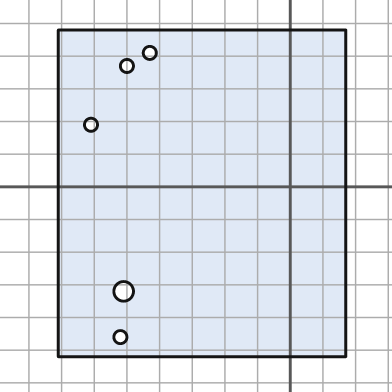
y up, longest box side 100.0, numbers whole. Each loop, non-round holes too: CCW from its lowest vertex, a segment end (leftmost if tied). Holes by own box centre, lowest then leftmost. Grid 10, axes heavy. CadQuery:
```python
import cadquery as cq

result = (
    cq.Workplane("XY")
    .moveTo(-71.0, -52.0)
    .lineTo(17.0, -52.0)
    .lineTo(17.0, 48.0)
    .lineTo(-71.0, 48.0)
    .close()
    .moveTo(-52.0, -46.0)
    .circle(2.0)
    .moveTo(-51.0, -32.0)
    .circle(3.0)
    .moveTo(-61.0, 19.0)
    .circle(2.0)
    .moveTo(-50.0, 37.0)
    .circle(2.0)
    .moveTo(-43.0, 41.0)
    .circle(2.0)
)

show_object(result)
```